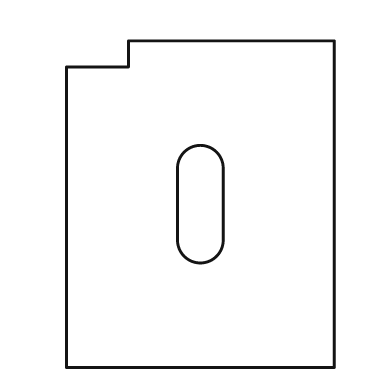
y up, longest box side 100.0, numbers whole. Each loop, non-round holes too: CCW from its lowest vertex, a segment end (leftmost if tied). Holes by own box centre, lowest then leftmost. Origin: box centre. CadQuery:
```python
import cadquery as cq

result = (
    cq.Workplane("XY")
    .moveTo(-41.0, -50.0)
    .lineTo(41.0, -50.0)
    .lineTo(41.0, 50.0)
    .lineTo(-22.0, 50.0)
    .lineTo(-22.0, 42.0)
    .lineTo(-41.0, 42.0)
    .close()
    .moveTo(-7.0, -11.0)
    .threePointArc((0.0, -18.0), (7.0, -11.0))
    .lineTo(7.0, 11.0)
    .threePointArc((0.0, 18.0), (-7.0, 11.0))
    .close()
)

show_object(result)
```